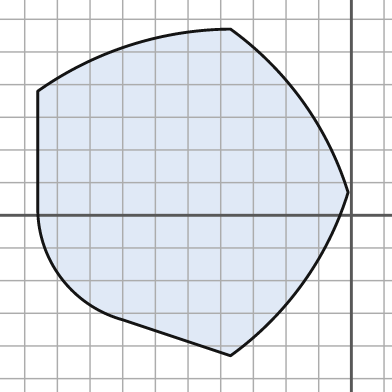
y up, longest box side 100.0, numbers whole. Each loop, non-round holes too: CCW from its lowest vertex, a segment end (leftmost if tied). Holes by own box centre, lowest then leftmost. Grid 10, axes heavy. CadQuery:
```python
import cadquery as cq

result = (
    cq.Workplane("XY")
    .moveTo(-37.0, -43.0)
    .threePointArc((-15.0, -21.0), (-1.0, 7.0))
    .threePointArc((-15.0, 35.0), (-37.0, 57.0))
    .threePointArc((-68.0, 52.0), (-96.0, 38.0))
    .lineTo(-96.0, 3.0)
    .threePointArc((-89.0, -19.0), (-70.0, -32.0))
    .close()
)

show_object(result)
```